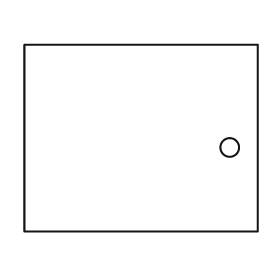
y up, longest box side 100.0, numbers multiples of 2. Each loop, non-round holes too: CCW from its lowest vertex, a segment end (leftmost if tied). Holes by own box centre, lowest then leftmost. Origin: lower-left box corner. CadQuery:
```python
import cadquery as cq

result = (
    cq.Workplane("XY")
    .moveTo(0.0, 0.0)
    .lineTo(100.0, 0.0)
    .lineTo(100.0, 80.0)
    .lineTo(0.0, 80.0)
    .close()
    .moveTo(88.0, 36.0)
    .circle(4.0)
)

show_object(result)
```